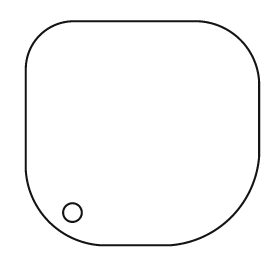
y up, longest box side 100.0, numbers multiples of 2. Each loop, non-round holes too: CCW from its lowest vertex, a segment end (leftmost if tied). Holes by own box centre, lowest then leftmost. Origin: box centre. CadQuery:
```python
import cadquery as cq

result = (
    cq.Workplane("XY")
    .moveTo(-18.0, -48.0)
    .lineTo(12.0, -48.0)
    .threePointArc((38.0, -36.0), (50.0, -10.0))
    .lineTo(50.0, 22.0)
    .threePointArc((42.0, 40.0), (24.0, 48.0))
    .lineTo(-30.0, 48.0)
    .threePointArc((-44.0, 42.0), (-50.0, 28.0))
    .lineTo(-50.0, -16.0)
    .threePointArc((-40.0, -38.0), (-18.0, -48.0))
    .close()
    .moveTo(-30.0, -34.0)
    .circle(4.0)
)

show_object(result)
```